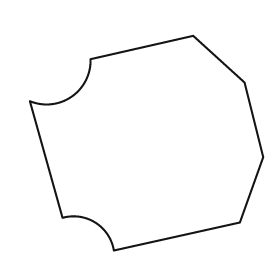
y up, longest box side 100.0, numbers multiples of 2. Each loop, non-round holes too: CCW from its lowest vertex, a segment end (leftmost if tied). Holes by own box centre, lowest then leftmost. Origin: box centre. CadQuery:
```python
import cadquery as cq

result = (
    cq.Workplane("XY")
    .moveTo(-14.0, -46.0)
    .lineTo(40.0, -34.0)
    .lineTo(50.0, -6.0)
    .lineTo(42.0, 26.0)
    .lineTo(20.0, 46.0)
    .lineTo(-24.0, 36.0)
    .threePointArc((-32.0, 20.0), (-50.0, 18.0))
    .lineTo(-36.0, -32.0)
    .threePointArc((-22.0, -34.0), (-14.0, -46.0))
    .close()
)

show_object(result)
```